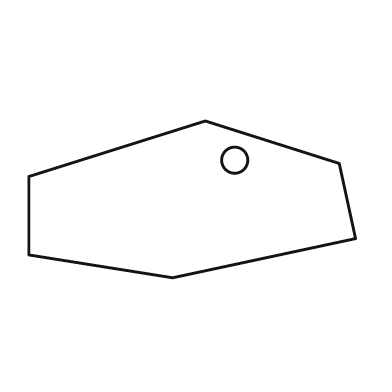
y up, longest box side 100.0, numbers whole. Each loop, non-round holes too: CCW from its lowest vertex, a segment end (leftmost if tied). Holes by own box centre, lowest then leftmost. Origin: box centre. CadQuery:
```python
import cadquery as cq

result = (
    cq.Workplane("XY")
    .moveTo(-6.0, -24.0)
    .lineTo(50.0, -12.0)
    .lineTo(45.0, 11.0)
    .lineTo(4.0, 24.0)
    .lineTo(-50.0, 7.0)
    .lineTo(-50.0, -17.0)
    .close()
    .moveTo(13.0, 12.0)
    .circle(4.0)
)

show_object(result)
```